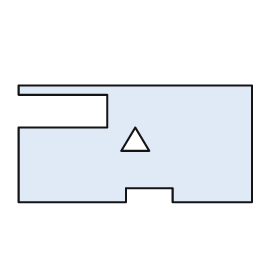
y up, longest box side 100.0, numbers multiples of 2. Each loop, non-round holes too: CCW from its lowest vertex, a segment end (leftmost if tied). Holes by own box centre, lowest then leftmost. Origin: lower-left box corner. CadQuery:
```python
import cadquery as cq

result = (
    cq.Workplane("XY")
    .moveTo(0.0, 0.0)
    .lineTo(46.0, 0.0)
    .lineTo(46.0, 6.0)
    .lineTo(66.0, 6.0)
    .lineTo(66.0, 0.0)
    .lineTo(100.0, 0.0)
    .lineTo(100.0, 50.0)
    .lineTo(0.0, 50.0)
    .lineTo(0.0, 46.0)
    .lineTo(38.0, 46.0)
    .lineTo(38.0, 32.0)
    .lineTo(0.0, 32.0)
    .close()
    .moveTo(44.0, 22.0)
    .lineTo(56.0, 22.0)
    .lineTo(50.0, 32.0)
    .close()
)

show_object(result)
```